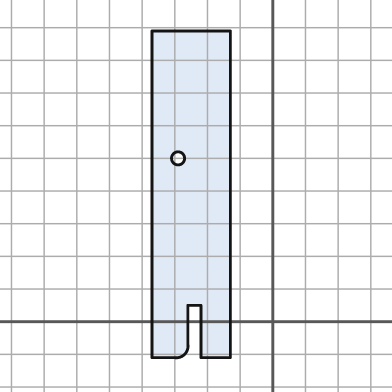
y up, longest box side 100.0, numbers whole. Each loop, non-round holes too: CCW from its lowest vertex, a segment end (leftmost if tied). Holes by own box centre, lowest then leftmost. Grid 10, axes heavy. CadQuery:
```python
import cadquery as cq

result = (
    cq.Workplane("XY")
    .moveTo(-37.0, -11.0)
    .lineTo(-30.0, -11.0)
    .threePointArc((-27.0, -10.0), (-26.0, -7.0))
    .lineTo(-26.0, 5.0)
    .lineTo(-22.0, 5.0)
    .lineTo(-22.0, -11.0)
    .lineTo(-13.0, -11.0)
    .lineTo(-13.0, 89.0)
    .lineTo(-37.0, 89.0)
    .close()
    .moveTo(-29.0, 50.0)
    .circle(2.0)
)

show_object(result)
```